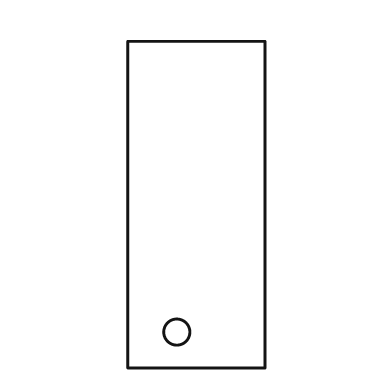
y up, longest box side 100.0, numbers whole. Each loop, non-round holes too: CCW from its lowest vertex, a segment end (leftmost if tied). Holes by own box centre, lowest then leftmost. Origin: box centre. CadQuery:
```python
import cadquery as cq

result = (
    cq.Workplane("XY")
    .moveTo(-21.0, -50.0)
    .lineTo(21.0, -50.0)
    .lineTo(21.0, 50.0)
    .lineTo(-21.0, 50.0)
    .close()
    .moveTo(-6.0, -39.0)
    .circle(4.0)
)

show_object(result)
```